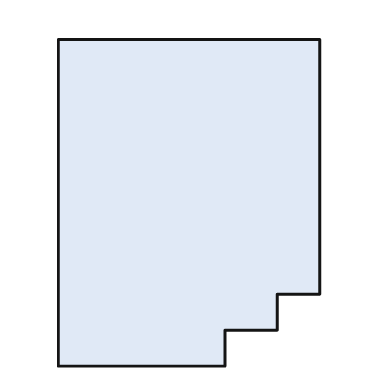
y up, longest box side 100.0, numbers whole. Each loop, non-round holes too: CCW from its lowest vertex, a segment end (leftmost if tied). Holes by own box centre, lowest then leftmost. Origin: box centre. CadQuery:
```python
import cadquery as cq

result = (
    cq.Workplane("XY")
    .moveTo(-40.0, -50.0)
    .lineTo(11.0, -50.0)
    .lineTo(11.0, -39.0)
    .lineTo(27.0, -39.0)
    .lineTo(27.0, -28.0)
    .lineTo(40.0, -28.0)
    .lineTo(40.0, 50.0)
    .lineTo(-40.0, 50.0)
    .close()
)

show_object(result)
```